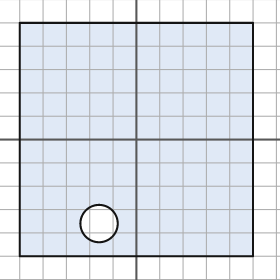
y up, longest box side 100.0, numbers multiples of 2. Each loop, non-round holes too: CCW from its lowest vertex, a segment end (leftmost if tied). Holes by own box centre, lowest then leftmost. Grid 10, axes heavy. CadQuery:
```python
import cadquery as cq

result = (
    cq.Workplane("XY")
    .moveTo(-50.0, -50.0)
    .lineTo(50.0, -50.0)
    .lineTo(50.0, 50.0)
    .lineTo(-50.0, 50.0)
    .close()
    .moveTo(-16.0, -36.0)
    .circle(8.0)
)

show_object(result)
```